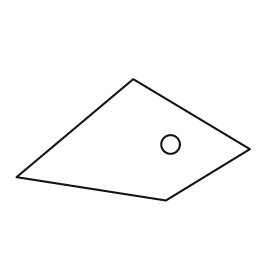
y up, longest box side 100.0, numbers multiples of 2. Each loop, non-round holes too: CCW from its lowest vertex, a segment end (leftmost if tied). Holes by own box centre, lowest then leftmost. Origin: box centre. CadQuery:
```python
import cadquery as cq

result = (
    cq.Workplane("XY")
    .moveTo(14.0, -26.0)
    .lineTo(50.0, -4.0)
    .lineTo(0.0, 26.0)
    .lineTo(-50.0, -16.0)
    .close()
    .moveTo(16.0, -2.0)
    .circle(4.0)
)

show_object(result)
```